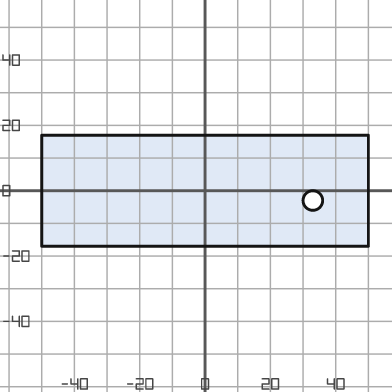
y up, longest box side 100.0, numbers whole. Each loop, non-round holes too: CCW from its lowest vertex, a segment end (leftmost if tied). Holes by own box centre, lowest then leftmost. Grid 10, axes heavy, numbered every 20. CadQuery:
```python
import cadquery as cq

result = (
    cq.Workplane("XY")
    .moveTo(-50.0, -17.0)
    .lineTo(50.0, -17.0)
    .lineTo(50.0, 17.0)
    .lineTo(-50.0, 17.0)
    .close()
    .moveTo(33.0, -3.0)
    .circle(3.0)
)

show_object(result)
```